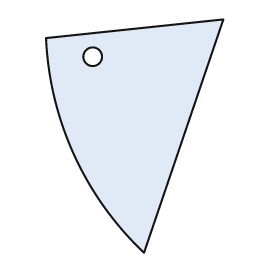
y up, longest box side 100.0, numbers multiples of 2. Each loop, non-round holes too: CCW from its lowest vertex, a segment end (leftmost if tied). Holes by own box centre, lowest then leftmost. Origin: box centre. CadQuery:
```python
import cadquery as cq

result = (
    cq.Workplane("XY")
    .moveTo(4.0, -50.0)
    .lineTo(38.0, 50.0)
    .lineTo(-38.0, 42.0)
    .threePointArc((-26.0, -8.0), (4.0, -50.0))
    .close()
    .moveTo(-18.0, 34.0)
    .circle(4.0)
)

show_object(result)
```